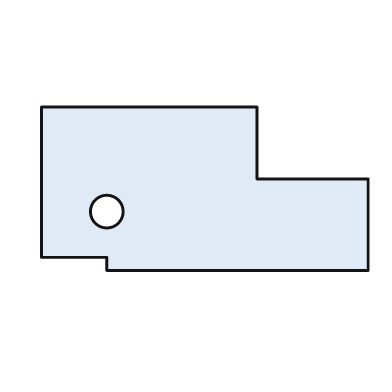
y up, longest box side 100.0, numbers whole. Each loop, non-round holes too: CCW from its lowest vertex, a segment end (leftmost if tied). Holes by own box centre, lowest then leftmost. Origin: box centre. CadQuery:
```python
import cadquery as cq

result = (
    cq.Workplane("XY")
    .moveTo(-30.0, -25.0)
    .lineTo(50.0, -25.0)
    .lineTo(50.0, 3.0)
    .lineTo(16.0, 3.0)
    .lineTo(16.0, 25.0)
    .lineTo(-50.0, 25.0)
    .lineTo(-50.0, -21.0)
    .lineTo(-30.0, -21.0)
    .close()
    .moveTo(-30.0, -7.0)
    .circle(5.0)
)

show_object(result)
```